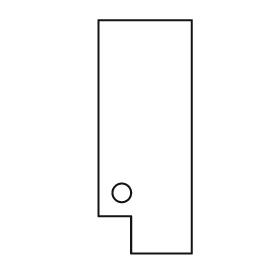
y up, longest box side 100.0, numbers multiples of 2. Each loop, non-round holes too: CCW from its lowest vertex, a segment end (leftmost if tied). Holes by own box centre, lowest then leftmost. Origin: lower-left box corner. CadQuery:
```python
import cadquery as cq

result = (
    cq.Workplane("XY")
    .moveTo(14.0, 0.0)
    .lineTo(40.0, 0.0)
    .lineTo(40.0, 100.0)
    .lineTo(0.0, 100.0)
    .lineTo(0.0, 16.0)
    .lineTo(14.0, 16.0)
    .close()
    .moveTo(10.0, 26.0)
    .circle(4.0)
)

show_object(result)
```